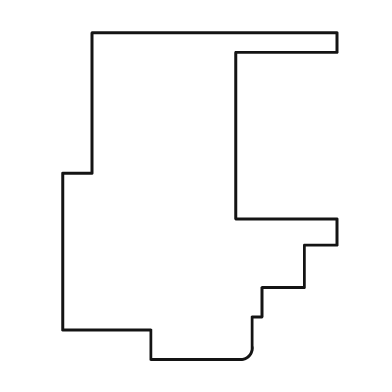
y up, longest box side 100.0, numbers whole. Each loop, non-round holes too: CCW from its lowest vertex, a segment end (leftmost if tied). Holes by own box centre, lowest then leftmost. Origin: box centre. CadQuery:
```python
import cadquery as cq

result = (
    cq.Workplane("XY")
    .moveTo(-15.0, -50.0)
    .lineTo(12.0, -50.0)
    .threePointArc((15.0, -49.0), (16.0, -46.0))
    .lineTo(16.0, -37.0)
    .lineTo(19.0, -37.0)
    .lineTo(19.0, -28.0)
    .lineTo(32.0, -28.0)
    .lineTo(32.0, -15.0)
    .lineTo(42.0, -15.0)
    .lineTo(42.0, -7.0)
    .lineTo(11.0, -7.0)
    .lineTo(11.0, 44.0)
    .lineTo(42.0, 44.0)
    .lineTo(42.0, 50.0)
    .lineTo(-33.0, 50.0)
    .lineTo(-33.0, 7.0)
    .lineTo(-42.0, 7.0)
    .lineTo(-42.0, -41.0)
    .lineTo(-15.0, -41.0)
    .close()
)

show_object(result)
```